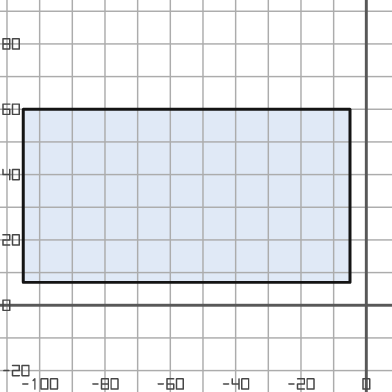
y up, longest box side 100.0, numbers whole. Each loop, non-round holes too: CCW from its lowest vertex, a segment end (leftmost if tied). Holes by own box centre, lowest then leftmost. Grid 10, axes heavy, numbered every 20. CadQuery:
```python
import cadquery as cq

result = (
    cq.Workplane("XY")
    .moveTo(-105.0, 7.0)
    .lineTo(-5.0, 7.0)
    .lineTo(-5.0, 60.0)
    .lineTo(-105.0, 60.0)
    .close()
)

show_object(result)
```